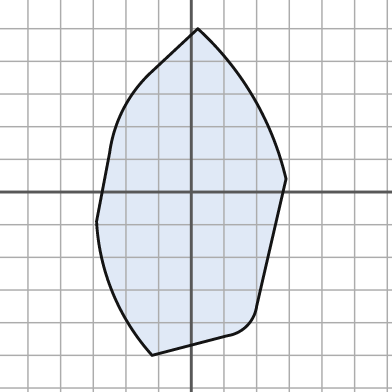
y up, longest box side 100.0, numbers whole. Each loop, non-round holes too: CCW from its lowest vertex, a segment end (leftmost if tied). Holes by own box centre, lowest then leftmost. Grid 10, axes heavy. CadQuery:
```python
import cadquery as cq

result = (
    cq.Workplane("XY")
    .moveTo(-12.0, -50.0)
    .lineTo(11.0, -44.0)
    .threePointArc((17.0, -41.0), (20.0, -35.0))
    .lineTo(29.0, 4.0)
    .threePointArc((19.0, 29.0), (2.0, 50.0))
    .lineTo(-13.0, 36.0)
    .threePointArc((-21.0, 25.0), (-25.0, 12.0))
    .lineTo(-29.0, -9.0)
    .threePointArc((-24.0, -31.0), (-12.0, -50.0))
    .close()
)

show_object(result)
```